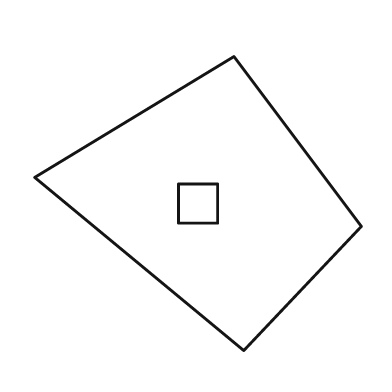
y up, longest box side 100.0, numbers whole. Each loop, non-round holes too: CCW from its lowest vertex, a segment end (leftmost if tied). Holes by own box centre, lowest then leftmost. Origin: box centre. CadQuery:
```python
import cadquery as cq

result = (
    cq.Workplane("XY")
    .moveTo(14.0, -45.0)
    .lineTo(50.0, -7.0)
    .lineTo(11.0, 45.0)
    .lineTo(-50.0, 8.0)
    .close()
    .moveTo(-6.0, -6.0)
    .lineTo(6.0, -6.0)
    .lineTo(6.0, 6.0)
    .lineTo(-6.0, 6.0)
    .close()
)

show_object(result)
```